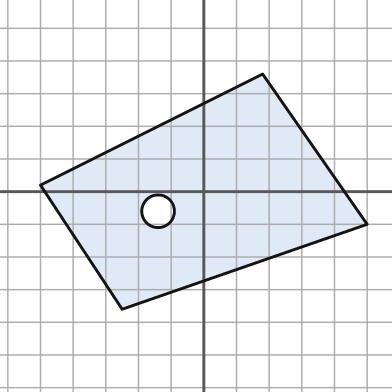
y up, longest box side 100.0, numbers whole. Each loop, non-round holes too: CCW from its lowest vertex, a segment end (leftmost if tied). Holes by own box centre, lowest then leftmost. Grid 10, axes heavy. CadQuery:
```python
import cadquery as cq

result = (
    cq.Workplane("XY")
    .moveTo(-25.0, -36.0)
    .lineTo(50.0, -10.0)
    .lineTo(18.0, 36.0)
    .lineTo(-50.0, 2.0)
    .close()
    .moveTo(-14.0, -6.0)
    .circle(5.0)
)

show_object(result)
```